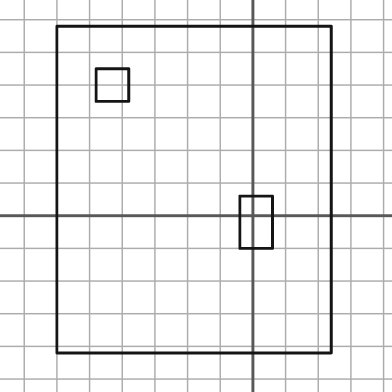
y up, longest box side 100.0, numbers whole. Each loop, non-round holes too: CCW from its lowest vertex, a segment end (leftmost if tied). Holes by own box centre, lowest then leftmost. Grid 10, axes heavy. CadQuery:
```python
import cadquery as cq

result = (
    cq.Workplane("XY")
    .moveTo(-60.0, -42.0)
    .lineTo(24.0, -42.0)
    .lineTo(24.0, 58.0)
    .lineTo(-60.0, 58.0)
    .close()
    .moveTo(-4.0, -10.0)
    .lineTo(6.0, -10.0)
    .lineTo(6.0, 6.0)
    .lineTo(-4.0, 6.0)
    .close()
    .moveTo(-48.0, 35.0)
    .lineTo(-38.0, 35.0)
    .lineTo(-38.0, 45.0)
    .lineTo(-48.0, 45.0)
    .close()
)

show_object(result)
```